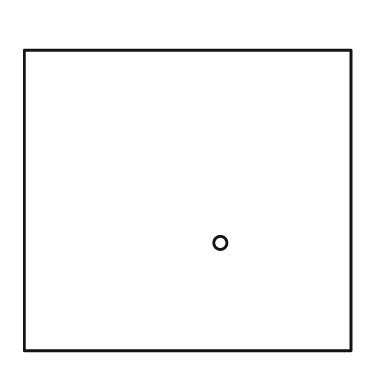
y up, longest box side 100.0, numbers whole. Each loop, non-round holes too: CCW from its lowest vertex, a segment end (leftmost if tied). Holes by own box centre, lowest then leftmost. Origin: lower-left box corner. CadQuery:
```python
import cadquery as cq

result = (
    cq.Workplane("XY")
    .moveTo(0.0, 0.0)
    .lineTo(100.0, 0.0)
    .lineTo(100.0, 92.0)
    .lineTo(0.0, 92.0)
    .close()
    .moveTo(60.0, 33.0)
    .circle(2.0)
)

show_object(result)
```